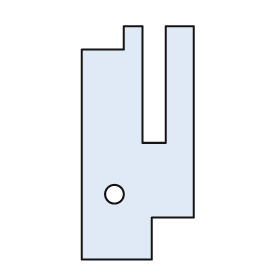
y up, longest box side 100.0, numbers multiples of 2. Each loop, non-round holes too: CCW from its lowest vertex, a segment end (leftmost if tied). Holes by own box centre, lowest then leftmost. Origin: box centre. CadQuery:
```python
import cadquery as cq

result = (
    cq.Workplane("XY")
    .moveTo(-24.0, -50.0)
    .lineTo(6.0, -50.0)
    .lineTo(6.0, -32.0)
    .lineTo(24.0, -32.0)
    .lineTo(24.0, 50.0)
    .lineTo(12.0, 50.0)
    .lineTo(12.0, 0.0)
    .lineTo(2.0, 0.0)
    .lineTo(2.0, 50.0)
    .lineTo(-6.0, 50.0)
    .lineTo(-6.0, 40.0)
    .lineTo(-24.0, 40.0)
    .close()
    .moveTo(-10.0, -22.0)
    .circle(4.0)
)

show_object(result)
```